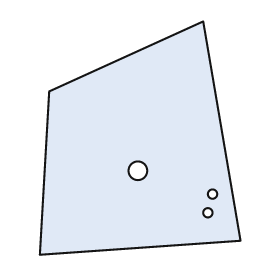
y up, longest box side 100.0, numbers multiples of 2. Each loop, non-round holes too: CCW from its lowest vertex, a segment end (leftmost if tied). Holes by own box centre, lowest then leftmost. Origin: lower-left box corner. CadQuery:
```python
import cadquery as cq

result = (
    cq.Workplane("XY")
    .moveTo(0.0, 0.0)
    .lineTo(86.0, 6.0)
    .lineTo(70.0, 100.0)
    .lineTo(4.0, 70.0)
    .close()
    .moveTo(72.0, 18.0)
    .circle(2.0)
    .moveTo(74.0, 26.0)
    .circle(2.0)
    .moveTo(42.0, 36.0)
    .circle(4.0)
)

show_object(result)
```